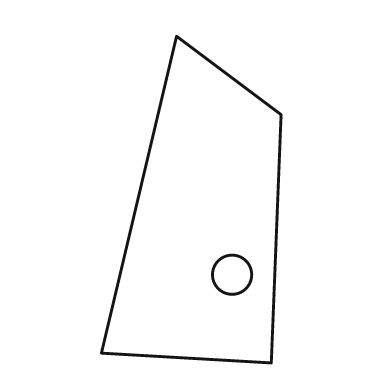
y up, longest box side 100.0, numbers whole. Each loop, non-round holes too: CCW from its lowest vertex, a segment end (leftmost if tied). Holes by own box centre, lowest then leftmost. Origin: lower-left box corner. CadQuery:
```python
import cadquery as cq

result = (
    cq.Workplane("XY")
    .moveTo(52.0, 0.0)
    .lineTo(55.0, 76.0)
    .lineTo(23.0, 100.0)
    .lineTo(0.0, 3.0)
    .close()
    .moveTo(40.0, 27.0)
    .circle(6.0)
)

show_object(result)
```